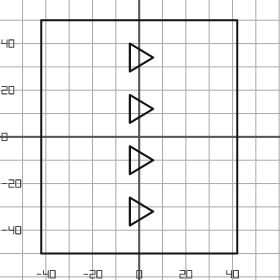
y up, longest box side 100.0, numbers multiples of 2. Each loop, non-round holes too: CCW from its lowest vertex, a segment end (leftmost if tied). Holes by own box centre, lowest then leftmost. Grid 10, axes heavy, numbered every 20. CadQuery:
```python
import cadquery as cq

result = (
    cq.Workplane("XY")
    .moveTo(-42.0, -50.0)
    .lineTo(42.0, -50.0)
    .lineTo(42.0, 50.0)
    .lineTo(-42.0, 50.0)
    .close()
    .moveTo(-4.0, -38.0)
    .lineTo(6.0, -32.0)
    .lineTo(-4.0, -26.0)
    .close()
    .moveTo(-4.0, -16.0)
    .lineTo(6.0, -10.0)
    .lineTo(-4.0, -4.0)
    .close()
    .moveTo(-4.0, 6.0)
    .lineTo(6.0, 12.0)
    .lineTo(-4.0, 18.0)
    .close()
    .moveTo(-4.0, 28.0)
    .lineTo(6.0, 34.0)
    .lineTo(-4.0, 40.0)
    .close()
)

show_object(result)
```